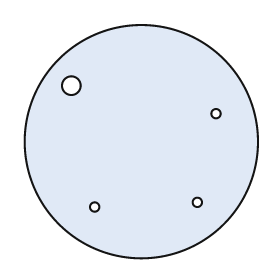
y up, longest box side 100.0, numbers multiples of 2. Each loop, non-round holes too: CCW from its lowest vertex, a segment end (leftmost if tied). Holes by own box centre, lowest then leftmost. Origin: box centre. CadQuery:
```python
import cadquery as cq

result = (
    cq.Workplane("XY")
    .moveTo(0.0, 0.0)
    .circle(50.0)
    .moveTo(-20.0, -28.0)
    .circle(2.0)
    .moveTo(24.0, -26.0)
    .circle(2.0)
    .moveTo(32.0, 12.0)
    .circle(2.0)
    .moveTo(-30.0, 24.0)
    .circle(4.0)
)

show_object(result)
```